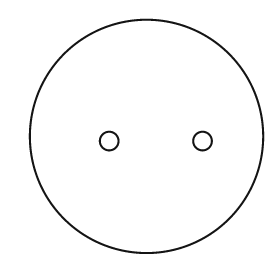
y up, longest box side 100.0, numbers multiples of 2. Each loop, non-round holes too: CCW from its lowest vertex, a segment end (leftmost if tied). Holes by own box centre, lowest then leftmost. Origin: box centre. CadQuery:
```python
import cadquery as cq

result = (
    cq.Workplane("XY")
    .moveTo(0.0, 0.0)
    .circle(50.0)
    .moveTo(-16.0, -2.0)
    .circle(4.0)
    .moveTo(24.0, -2.0)
    .circle(4.0)
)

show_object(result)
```